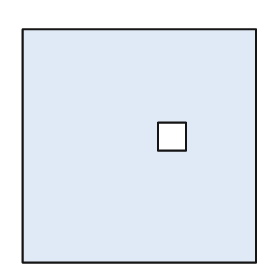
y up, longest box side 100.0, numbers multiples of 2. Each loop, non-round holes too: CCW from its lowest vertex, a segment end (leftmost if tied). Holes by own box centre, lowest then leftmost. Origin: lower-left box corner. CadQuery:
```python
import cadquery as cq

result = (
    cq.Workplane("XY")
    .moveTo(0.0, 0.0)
    .lineTo(100.0, 0.0)
    .lineTo(100.0, 100.0)
    .lineTo(0.0, 100.0)
    .close()
    .moveTo(58.0, 48.0)
    .lineTo(70.0, 48.0)
    .lineTo(70.0, 60.0)
    .lineTo(58.0, 60.0)
    .close()
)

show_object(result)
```